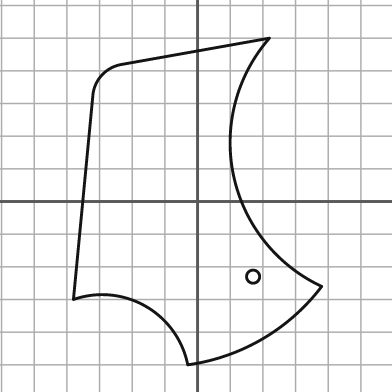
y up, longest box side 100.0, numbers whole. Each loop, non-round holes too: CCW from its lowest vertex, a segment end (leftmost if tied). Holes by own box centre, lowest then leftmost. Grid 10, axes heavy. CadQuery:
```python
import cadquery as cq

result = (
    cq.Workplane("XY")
    .moveTo(-3.0, -50.0)
    .threePointArc((20.0, -42.0), (38.0, -26.0))
    .threePointArc((11.0, 8.0), (22.0, 50.0))
    .lineTo(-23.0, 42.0)
    .threePointArc((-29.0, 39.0), (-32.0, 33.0))
    .lineTo(-38.0, -30.0)
    .threePointArc((-16.0, -32.0), (-3.0, -50.0))
    .close()
    .moveTo(17.0, -23.0)
    .circle(2.0)
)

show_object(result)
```